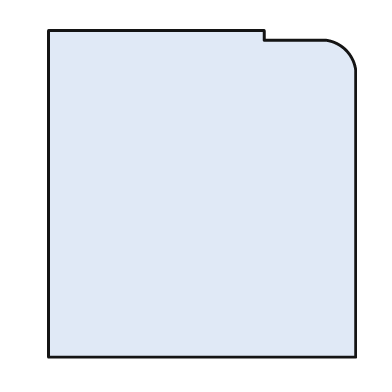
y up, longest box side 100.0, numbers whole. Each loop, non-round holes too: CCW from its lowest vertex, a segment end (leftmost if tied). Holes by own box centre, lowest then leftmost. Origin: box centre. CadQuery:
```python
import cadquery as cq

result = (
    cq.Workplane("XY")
    .moveTo(-47.0, -50.0)
    .lineTo(47.0, -50.0)
    .lineTo(47.0, 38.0)
    .threePointArc((44.0, 44.0), (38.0, 47.0))
    .lineTo(19.0, 47.0)
    .lineTo(19.0, 50.0)
    .lineTo(-47.0, 50.0)
    .close()
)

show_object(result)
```